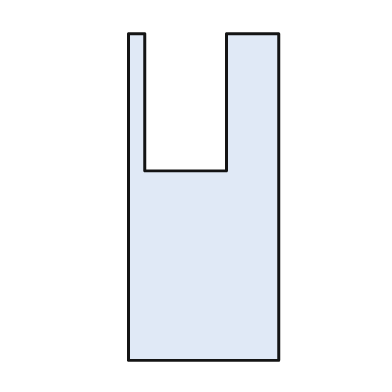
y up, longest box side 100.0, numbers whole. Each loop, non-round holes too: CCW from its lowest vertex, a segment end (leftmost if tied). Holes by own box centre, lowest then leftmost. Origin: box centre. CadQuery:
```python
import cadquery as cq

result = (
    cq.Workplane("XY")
    .moveTo(-23.0, -50.0)
    .lineTo(23.0, -50.0)
    .lineTo(23.0, 50.0)
    .lineTo(7.0, 50.0)
    .lineTo(7.0, 8.0)
    .lineTo(-18.0, 8.0)
    .lineTo(-18.0, 50.0)
    .lineTo(-23.0, 50.0)
    .close()
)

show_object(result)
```